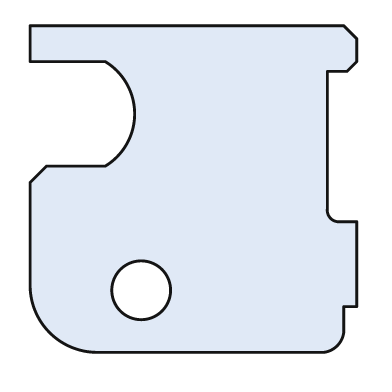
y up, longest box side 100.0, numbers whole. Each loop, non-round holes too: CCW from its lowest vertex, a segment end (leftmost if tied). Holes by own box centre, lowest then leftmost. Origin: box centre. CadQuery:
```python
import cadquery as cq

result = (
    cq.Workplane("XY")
    .moveTo(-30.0, -50.0)
    .lineTo(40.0, -50.0)
    .threePointArc((44.0, -48.0), (46.0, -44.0))
    .lineTo(46.0, -36.0)
    .lineTo(50.0, -36.0)
    .lineTo(50.0, -10.0)
    .lineTo(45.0, -10.0)
    .threePointArc((42.0, -9.0), (41.0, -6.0))
    .lineTo(41.0, 36.0)
    .lineTo(47.0, 36.0)
    .lineTo(50.0, 39.0)
    .lineTo(50.0, 46.0)
    .lineTo(46.0, 50.0)
    .lineTo(-50.0, 50.0)
    .lineTo(-50.0, 39.0)
    .lineTo(-27.0, 39.0)
    .threePointArc((-18.0, 23.0), (-27.0, 7.0))
    .lineTo(-45.0, 7.0)
    .lineTo(-50.0, 2.0)
    .lineTo(-50.0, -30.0)
    .threePointArc((-44.0, -44.0), (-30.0, -50.0))
    .close()
    .moveTo(-16.0, -31.0)
    .circle(9.0)
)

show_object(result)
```